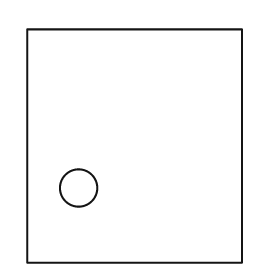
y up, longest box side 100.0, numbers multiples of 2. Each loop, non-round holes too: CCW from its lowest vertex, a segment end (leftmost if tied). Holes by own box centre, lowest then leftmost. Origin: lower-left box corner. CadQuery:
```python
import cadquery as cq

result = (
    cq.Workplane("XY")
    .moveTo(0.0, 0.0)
    .lineTo(92.0, 0.0)
    .lineTo(92.0, 100.0)
    .lineTo(0.0, 100.0)
    .close()
    .moveTo(22.0, 32.0)
    .circle(8.0)
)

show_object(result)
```